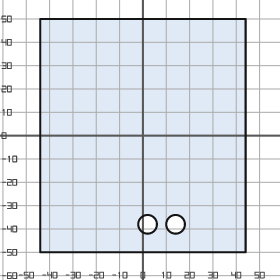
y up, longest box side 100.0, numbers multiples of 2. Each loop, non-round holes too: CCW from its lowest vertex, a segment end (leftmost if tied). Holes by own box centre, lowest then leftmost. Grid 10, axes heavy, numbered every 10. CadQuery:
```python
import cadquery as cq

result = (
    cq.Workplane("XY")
    .moveTo(-44.0, -50.0)
    .lineTo(44.0, -50.0)
    .lineTo(44.0, 50.0)
    .lineTo(-44.0, 50.0)
    .close()
    .moveTo(2.0, -38.0)
    .circle(4.0)
    .moveTo(14.0, -38.0)
    .circle(4.0)
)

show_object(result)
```